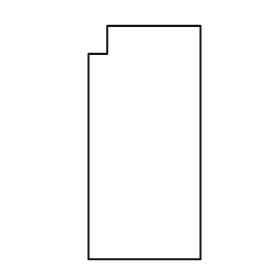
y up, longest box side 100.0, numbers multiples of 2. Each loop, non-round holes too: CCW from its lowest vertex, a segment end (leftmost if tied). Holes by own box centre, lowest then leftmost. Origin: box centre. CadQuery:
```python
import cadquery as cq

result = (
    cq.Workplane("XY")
    .moveTo(-24.0, -50.0)
    .lineTo(24.0, -50.0)
    .lineTo(24.0, 50.0)
    .lineTo(-16.0, 50.0)
    .lineTo(-16.0, 38.0)
    .lineTo(-24.0, 38.0)
    .close()
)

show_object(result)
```